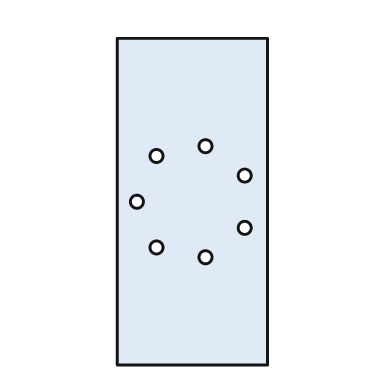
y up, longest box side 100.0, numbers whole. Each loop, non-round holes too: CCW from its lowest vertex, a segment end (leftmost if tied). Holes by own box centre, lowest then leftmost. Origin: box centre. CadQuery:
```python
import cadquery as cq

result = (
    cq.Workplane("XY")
    .moveTo(-23.0, -50.0)
    .lineTo(23.0, -50.0)
    .lineTo(23.0, 50.0)
    .lineTo(-23.0, 50.0)
    .close()
    .moveTo(4.0, -17.0)
    .circle(2.0)
    .moveTo(-11.0, -14.0)
    .circle(2.0)
    .moveTo(16.0, -8.0)
    .circle(2.0)
    .moveTo(-17.0, 0.0)
    .circle(2.0)
    .moveTo(16.0, 8.0)
    .circle(2.0)
    .moveTo(-11.0, 14.0)
    .circle(2.0)
    .moveTo(4.0, 17.0)
    .circle(2.0)
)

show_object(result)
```